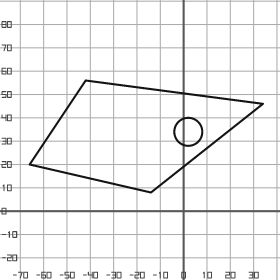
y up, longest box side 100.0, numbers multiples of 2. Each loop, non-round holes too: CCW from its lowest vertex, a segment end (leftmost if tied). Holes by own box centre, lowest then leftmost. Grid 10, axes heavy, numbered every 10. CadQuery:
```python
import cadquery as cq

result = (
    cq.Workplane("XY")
    .moveTo(-14.0, 8.0)
    .lineTo(34.0, 46.0)
    .lineTo(-42.0, 56.0)
    .lineTo(-66.0, 20.0)
    .close()
    .moveTo(2.0, 34.0)
    .circle(6.0)
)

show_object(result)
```